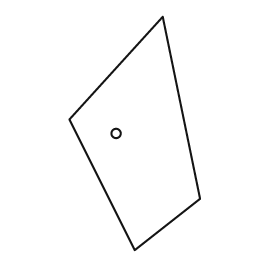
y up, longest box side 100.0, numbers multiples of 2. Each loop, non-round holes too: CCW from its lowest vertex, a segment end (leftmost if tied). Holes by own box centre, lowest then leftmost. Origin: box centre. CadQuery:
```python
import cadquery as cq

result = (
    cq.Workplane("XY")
    .moveTo(0.0, -50.0)
    .lineTo(28.0, -28.0)
    .lineTo(12.0, 50.0)
    .lineTo(-28.0, 6.0)
    .close()
    .moveTo(-8.0, 0.0)
    .circle(2.0)
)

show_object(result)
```